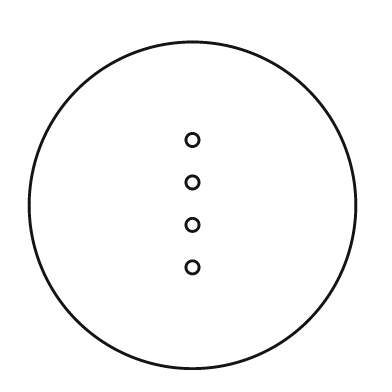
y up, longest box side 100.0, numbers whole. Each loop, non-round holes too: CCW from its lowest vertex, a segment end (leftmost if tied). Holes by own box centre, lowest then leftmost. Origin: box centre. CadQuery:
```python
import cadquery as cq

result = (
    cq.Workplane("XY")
    .moveTo(0.0, 0.0)
    .circle(50.0)
    .moveTo(0.0, -19.0)
    .circle(2.0)
    .moveTo(0.0, -6.0)
    .circle(2.0)
    .moveTo(0.0, 7.0)
    .circle(2.0)
    .moveTo(0.0, 20.0)
    .circle(2.0)
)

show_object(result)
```